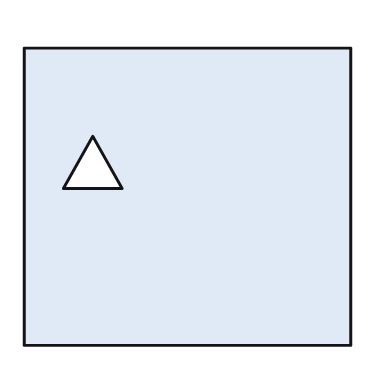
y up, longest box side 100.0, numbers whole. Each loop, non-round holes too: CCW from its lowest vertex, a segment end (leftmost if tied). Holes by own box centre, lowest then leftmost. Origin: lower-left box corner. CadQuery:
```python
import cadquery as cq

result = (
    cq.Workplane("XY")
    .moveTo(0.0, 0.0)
    .lineTo(100.0, 0.0)
    .lineTo(100.0, 91.0)
    .lineTo(0.0, 91.0)
    .close()
    .moveTo(12.0, 48.0)
    .lineTo(30.0, 48.0)
    .lineTo(21.0, 64.0)
    .close()
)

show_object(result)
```